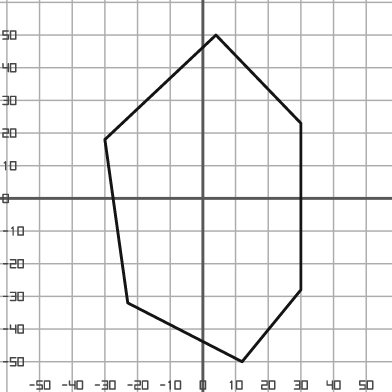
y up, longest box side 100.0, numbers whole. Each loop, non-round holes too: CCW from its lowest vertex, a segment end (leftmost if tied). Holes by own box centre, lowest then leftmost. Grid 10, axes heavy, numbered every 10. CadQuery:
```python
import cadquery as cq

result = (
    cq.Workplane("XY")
    .moveTo(12.0, -50.0)
    .lineTo(30.0, -28.0)
    .lineTo(30.0, 23.0)
    .lineTo(4.0, 50.0)
    .lineTo(-30.0, 18.0)
    .lineTo(-23.0, -32.0)
    .close()
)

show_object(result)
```